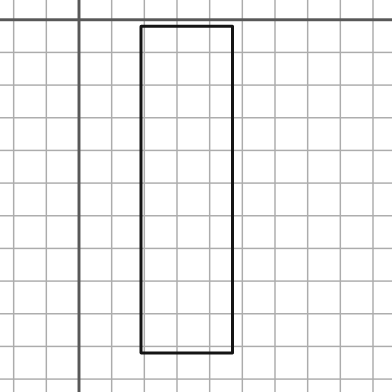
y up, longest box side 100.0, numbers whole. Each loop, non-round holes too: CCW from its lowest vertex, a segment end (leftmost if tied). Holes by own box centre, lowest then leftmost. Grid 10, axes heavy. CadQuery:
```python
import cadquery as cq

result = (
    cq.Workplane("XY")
    .moveTo(19.0, -102.0)
    .lineTo(47.0, -102.0)
    .lineTo(47.0, -2.0)
    .lineTo(19.0, -2.0)
    .close()
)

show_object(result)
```